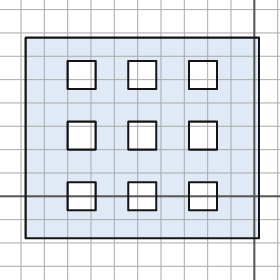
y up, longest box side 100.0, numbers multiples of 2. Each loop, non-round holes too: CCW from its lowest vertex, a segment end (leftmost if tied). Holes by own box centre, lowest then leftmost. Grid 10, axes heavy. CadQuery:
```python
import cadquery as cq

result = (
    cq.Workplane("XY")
    .moveTo(-98.0, -18.0)
    .lineTo(2.0, -18.0)
    .lineTo(2.0, 68.0)
    .lineTo(-98.0, 68.0)
    .close()
    .moveTo(-80.0, -6.0)
    .lineTo(-68.0, -6.0)
    .lineTo(-68.0, 6.0)
    .lineTo(-80.0, 6.0)
    .close()
    .moveTo(-54.0, -6.0)
    .lineTo(-42.0, -6.0)
    .lineTo(-42.0, 6.0)
    .lineTo(-54.0, 6.0)
    .close()
    .moveTo(-28.0, -6.0)
    .lineTo(-16.0, -6.0)
    .lineTo(-16.0, 6.0)
    .lineTo(-28.0, 6.0)
    .close()
    .moveTo(-80.0, 20.0)
    .lineTo(-68.0, 20.0)
    .lineTo(-68.0, 32.0)
    .lineTo(-80.0, 32.0)
    .close()
    .moveTo(-54.0, 20.0)
    .lineTo(-42.0, 20.0)
    .lineTo(-42.0, 32.0)
    .lineTo(-54.0, 32.0)
    .close()
    .moveTo(-28.0, 20.0)
    .lineTo(-16.0, 20.0)
    .lineTo(-16.0, 32.0)
    .lineTo(-28.0, 32.0)
    .close()
    .moveTo(-80.0, 46.0)
    .lineTo(-68.0, 46.0)
    .lineTo(-68.0, 58.0)
    .lineTo(-80.0, 58.0)
    .close()
    .moveTo(-54.0, 46.0)
    .lineTo(-42.0, 46.0)
    .lineTo(-42.0, 58.0)
    .lineTo(-54.0, 58.0)
    .close()
    .moveTo(-28.0, 46.0)
    .lineTo(-16.0, 46.0)
    .lineTo(-16.0, 58.0)
    .lineTo(-28.0, 58.0)
    .close()
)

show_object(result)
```